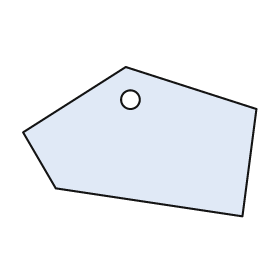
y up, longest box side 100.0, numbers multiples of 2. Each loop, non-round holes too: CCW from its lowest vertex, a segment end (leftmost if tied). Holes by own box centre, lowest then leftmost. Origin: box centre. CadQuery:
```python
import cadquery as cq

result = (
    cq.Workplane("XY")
    .moveTo(44.0, -32.0)
    .lineTo(50.0, 14.0)
    .lineTo(-6.0, 32.0)
    .lineTo(-50.0, 4.0)
    .lineTo(-36.0, -20.0)
    .close()
    .moveTo(-4.0, 18.0)
    .circle(4.0)
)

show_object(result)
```